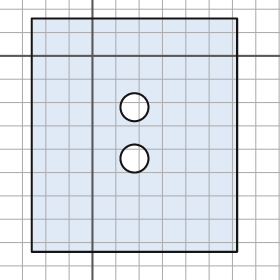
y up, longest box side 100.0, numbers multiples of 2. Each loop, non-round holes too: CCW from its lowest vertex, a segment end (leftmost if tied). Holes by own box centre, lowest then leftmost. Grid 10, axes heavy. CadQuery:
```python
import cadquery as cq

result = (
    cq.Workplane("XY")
    .moveTo(-26.0, -84.0)
    .lineTo(62.0, -84.0)
    .lineTo(62.0, 16.0)
    .lineTo(-26.0, 16.0)
    .close()
    .moveTo(18.0, -44.0)
    .circle(6.0)
    .moveTo(18.0, -22.0)
    .circle(6.0)
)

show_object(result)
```